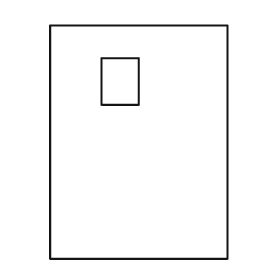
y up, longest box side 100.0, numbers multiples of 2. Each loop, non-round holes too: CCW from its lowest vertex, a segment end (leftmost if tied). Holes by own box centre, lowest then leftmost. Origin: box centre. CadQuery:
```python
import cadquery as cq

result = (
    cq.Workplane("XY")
    .moveTo(-38.0, -50.0)
    .lineTo(38.0, -50.0)
    .lineTo(38.0, 50.0)
    .lineTo(-38.0, 50.0)
    .close()
    .moveTo(-16.0, 16.0)
    .lineTo(0.0, 16.0)
    .lineTo(0.0, 36.0)
    .lineTo(-16.0, 36.0)
    .close()
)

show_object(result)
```